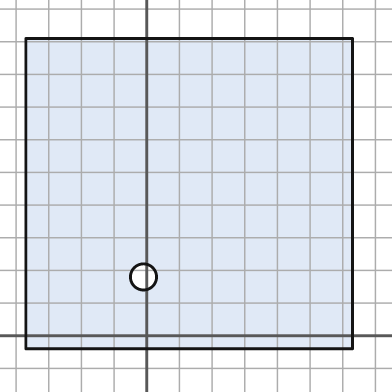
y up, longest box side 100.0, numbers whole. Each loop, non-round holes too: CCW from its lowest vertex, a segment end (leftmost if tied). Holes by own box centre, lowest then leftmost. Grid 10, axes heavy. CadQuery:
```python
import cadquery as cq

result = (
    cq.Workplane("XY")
    .moveTo(-37.0, -4.0)
    .lineTo(63.0, -4.0)
    .lineTo(63.0, 91.0)
    .lineTo(-37.0, 91.0)
    .close()
    .moveTo(-1.0, 18.0)
    .circle(4.0)
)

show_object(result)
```